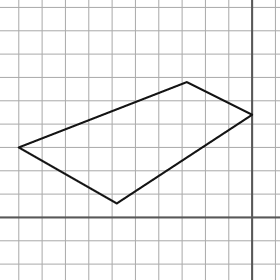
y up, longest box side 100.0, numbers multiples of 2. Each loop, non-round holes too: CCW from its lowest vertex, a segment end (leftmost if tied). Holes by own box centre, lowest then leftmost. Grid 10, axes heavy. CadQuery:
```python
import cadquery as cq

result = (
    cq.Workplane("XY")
    .moveTo(-58.0, 6.0)
    .lineTo(0.0, 44.0)
    .lineTo(-28.0, 58.0)
    .lineTo(-100.0, 30.0)
    .close()
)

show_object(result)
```